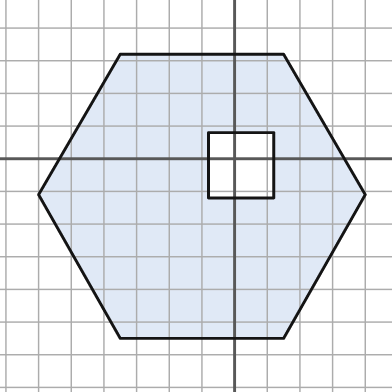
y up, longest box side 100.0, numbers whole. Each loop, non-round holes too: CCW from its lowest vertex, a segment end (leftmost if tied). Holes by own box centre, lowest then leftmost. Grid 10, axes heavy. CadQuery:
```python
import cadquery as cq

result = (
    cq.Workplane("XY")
    .moveTo(-35.0, -55.0)
    .lineTo(15.0, -55.0)
    .lineTo(40.0, -11.0)
    .lineTo(15.0, 32.0)
    .lineTo(-35.0, 32.0)
    .lineTo(-60.0, -11.0)
    .close()
    .moveTo(-8.0, -12.0)
    .lineTo(12.0, -12.0)
    .lineTo(12.0, 8.0)
    .lineTo(-8.0, 8.0)
    .close()
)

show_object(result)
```